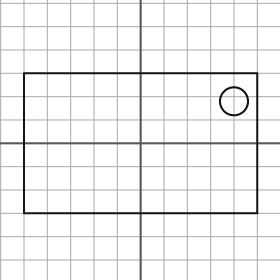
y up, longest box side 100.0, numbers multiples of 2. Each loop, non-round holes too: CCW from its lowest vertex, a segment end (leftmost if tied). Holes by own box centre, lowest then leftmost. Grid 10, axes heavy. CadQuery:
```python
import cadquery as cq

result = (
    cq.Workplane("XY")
    .moveTo(-50.0, -30.0)
    .lineTo(50.0, -30.0)
    .lineTo(50.0, 30.0)
    .lineTo(-50.0, 30.0)
    .close()
    .moveTo(40.0, 18.0)
    .circle(6.0)
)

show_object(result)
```